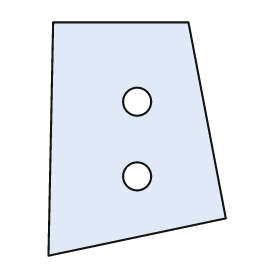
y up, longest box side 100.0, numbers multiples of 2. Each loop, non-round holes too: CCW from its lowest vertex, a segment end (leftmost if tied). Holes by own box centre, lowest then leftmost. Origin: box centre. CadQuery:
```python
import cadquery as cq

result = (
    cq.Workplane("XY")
    .moveTo(-38.0, -50.0)
    .lineTo(38.0, -34.0)
    .lineTo(22.0, 50.0)
    .lineTo(-36.0, 50.0)
    .close()
    .moveTo(0.0, -16.0)
    .circle(6.0)
    .moveTo(0.0, 16.0)
    .circle(6.0)
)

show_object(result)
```